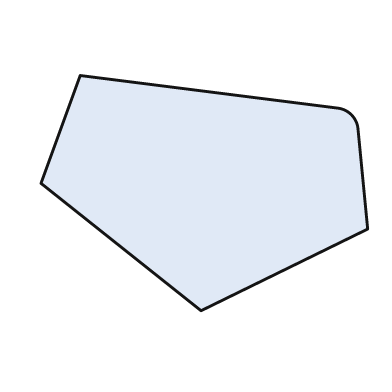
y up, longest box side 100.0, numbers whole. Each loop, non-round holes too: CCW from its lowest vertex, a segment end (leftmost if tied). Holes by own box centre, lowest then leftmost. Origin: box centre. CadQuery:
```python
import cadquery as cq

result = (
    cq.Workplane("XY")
    .moveTo(-1.0, -36.0)
    .lineTo(50.0, -11.0)
    .lineTo(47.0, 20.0)
    .threePointArc((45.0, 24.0), (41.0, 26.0))
    .lineTo(-38.0, 36.0)
    .lineTo(-50.0, 3.0)
    .close()
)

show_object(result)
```